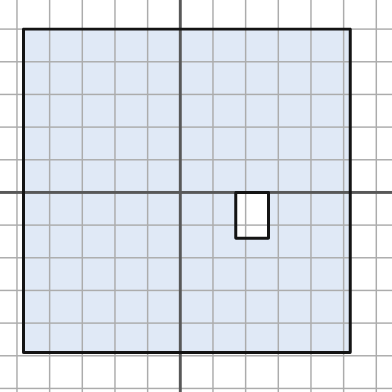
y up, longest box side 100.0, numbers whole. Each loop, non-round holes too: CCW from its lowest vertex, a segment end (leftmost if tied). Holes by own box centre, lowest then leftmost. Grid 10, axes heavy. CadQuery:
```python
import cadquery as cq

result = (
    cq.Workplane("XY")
    .moveTo(-48.0, -49.0)
    .lineTo(52.0, -49.0)
    .lineTo(52.0, 50.0)
    .lineTo(-48.0, 50.0)
    .close()
    .moveTo(17.0, -14.0)
    .lineTo(27.0, -14.0)
    .lineTo(27.0, 0.0)
    .lineTo(17.0, 0.0)
    .close()
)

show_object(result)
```